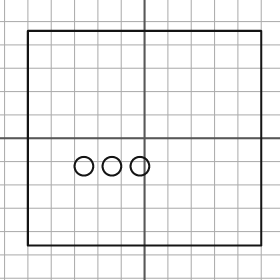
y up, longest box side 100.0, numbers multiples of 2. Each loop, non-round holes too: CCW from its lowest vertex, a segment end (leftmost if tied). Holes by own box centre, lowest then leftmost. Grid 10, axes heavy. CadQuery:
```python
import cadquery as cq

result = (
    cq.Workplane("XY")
    .moveTo(-50.0, -46.0)
    .lineTo(50.0, -46.0)
    .lineTo(50.0, 46.0)
    .lineTo(-50.0, 46.0)
    .close()
    .moveTo(-26.0, -12.0)
    .circle(4.0)
    .moveTo(-14.0, -12.0)
    .circle(4.0)
    .moveTo(-2.0, -12.0)
    .circle(4.0)
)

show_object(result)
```